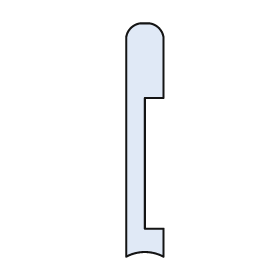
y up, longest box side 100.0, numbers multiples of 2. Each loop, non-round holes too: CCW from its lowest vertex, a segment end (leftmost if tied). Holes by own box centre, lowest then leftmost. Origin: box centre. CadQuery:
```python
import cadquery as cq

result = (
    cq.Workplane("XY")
    .moveTo(-8.0, -50.0)
    .threePointArc((0.0, -48.0), (8.0, -50.0))
    .lineTo(8.0, -38.0)
    .lineTo(0.0, -38.0)
    .lineTo(0.0, 18.0)
    .lineTo(8.0, 18.0)
    .lineTo(8.0, 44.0)
    .threePointArc((6.0, 48.0), (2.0, 50.0))
    .lineTo(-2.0, 50.0)
    .threePointArc((-6.0, 48.0), (-8.0, 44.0))
    .close()
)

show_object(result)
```